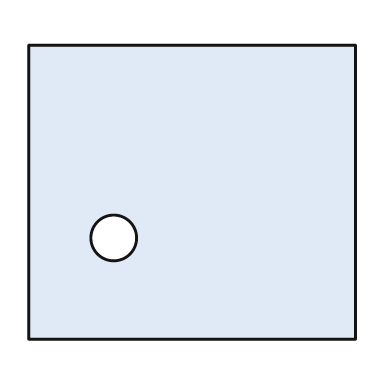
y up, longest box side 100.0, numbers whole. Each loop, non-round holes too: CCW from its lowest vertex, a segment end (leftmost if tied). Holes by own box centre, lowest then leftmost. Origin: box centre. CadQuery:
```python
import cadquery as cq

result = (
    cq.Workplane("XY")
    .moveTo(-50.0, -45.0)
    .lineTo(50.0, -45.0)
    .lineTo(50.0, 45.0)
    .lineTo(-50.0, 45.0)
    .close()
    .moveTo(-24.0, -14.0)
    .circle(7.0)
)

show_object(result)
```